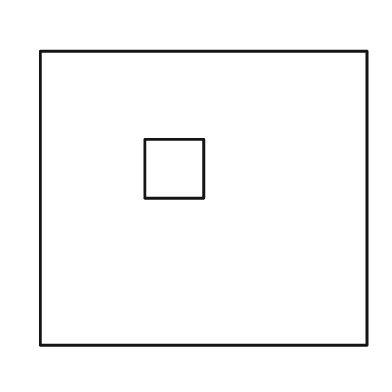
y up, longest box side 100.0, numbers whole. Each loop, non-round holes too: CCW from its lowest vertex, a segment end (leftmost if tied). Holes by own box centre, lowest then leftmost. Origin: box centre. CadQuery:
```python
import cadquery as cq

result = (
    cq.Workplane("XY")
    .moveTo(-50.0, -45.0)
    .lineTo(50.0, -45.0)
    .lineTo(50.0, 45.0)
    .lineTo(-50.0, 45.0)
    .close()
    .moveTo(-18.0, 0.0)
    .lineTo(0.0, 0.0)
    .lineTo(0.0, 18.0)
    .lineTo(-18.0, 18.0)
    .close()
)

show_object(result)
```